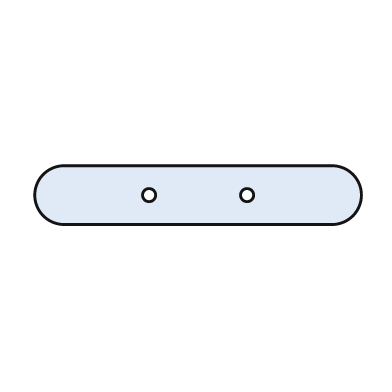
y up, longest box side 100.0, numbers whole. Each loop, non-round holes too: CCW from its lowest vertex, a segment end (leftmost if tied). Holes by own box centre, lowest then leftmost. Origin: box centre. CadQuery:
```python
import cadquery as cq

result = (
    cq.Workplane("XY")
    .moveTo(-41.0, -9.0)
    .lineTo(41.0, -9.0)
    .threePointArc((50.0, 0.0), (41.0, 9.0))
    .lineTo(-41.0, 9.0)
    .threePointArc((-50.0, 0.0), (-41.0, -9.0))
    .close()
    .moveTo(-15.0, 0.0)
    .circle(2.0)
    .moveTo(15.0, 0.0)
    .circle(2.0)
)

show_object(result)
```